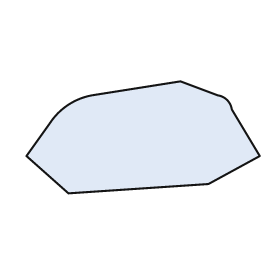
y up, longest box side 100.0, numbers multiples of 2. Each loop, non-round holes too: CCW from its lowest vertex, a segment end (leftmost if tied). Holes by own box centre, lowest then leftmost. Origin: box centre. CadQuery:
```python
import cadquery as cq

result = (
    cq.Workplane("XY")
    .moveTo(-32.0, -24.0)
    .lineTo(28.0, -20.0)
    .lineTo(50.0, -8.0)
    .lineTo(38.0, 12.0)
    .threePointArc((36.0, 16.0), (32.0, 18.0))
    .lineTo(16.0, 24.0)
    .lineTo(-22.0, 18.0)
    .threePointArc((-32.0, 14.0), (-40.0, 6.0))
    .lineTo(-50.0, -8.0)
    .close()
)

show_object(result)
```